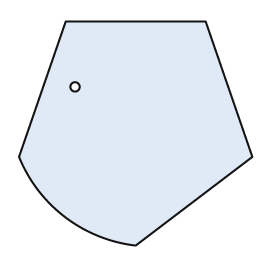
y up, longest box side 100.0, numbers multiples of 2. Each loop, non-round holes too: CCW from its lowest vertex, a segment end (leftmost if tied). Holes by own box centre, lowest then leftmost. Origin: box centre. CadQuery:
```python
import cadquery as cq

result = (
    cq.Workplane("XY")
    .moveTo(0.0, -48.0)
    .lineTo(50.0, -10.0)
    .lineTo(30.0, 48.0)
    .lineTo(-30.0, 48.0)
    .lineTo(-50.0, -10.0)
    .threePointArc((-30.0, -36.0), (0.0, -48.0))
    .close()
    .moveTo(-26.0, 20.0)
    .circle(2.0)
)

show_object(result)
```